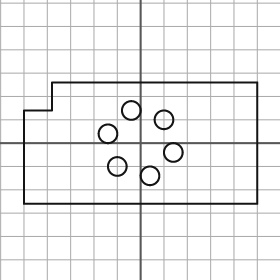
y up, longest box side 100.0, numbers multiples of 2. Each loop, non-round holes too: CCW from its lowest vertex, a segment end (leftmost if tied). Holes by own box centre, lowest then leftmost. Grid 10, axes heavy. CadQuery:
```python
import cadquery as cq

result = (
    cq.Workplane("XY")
    .moveTo(-50.0, -26.0)
    .lineTo(50.0, -26.0)
    .lineTo(50.0, 26.0)
    .lineTo(-38.0, 26.0)
    .lineTo(-38.0, 14.0)
    .lineTo(-50.0, 14.0)
    .close()
    .moveTo(4.0, -14.0)
    .circle(4.0)
    .moveTo(-10.0, -10.0)
    .circle(4.0)
    .moveTo(14.0, -4.0)
    .circle(4.0)
    .moveTo(-14.0, 4.0)
    .circle(4.0)
    .moveTo(10.0, 10.0)
    .circle(4.0)
    .moveTo(-4.0, 14.0)
    .circle(4.0)
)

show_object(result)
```